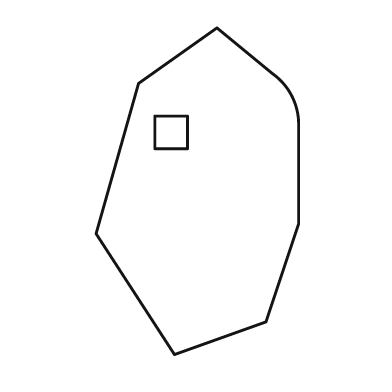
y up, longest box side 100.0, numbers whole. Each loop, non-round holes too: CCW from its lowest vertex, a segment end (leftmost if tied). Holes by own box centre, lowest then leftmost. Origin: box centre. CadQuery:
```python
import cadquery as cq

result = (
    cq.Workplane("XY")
    .moveTo(-7.0, -50.0)
    .lineTo(21.0, -40.0)
    .lineTo(31.0, -10.0)
    .lineTo(31.0, 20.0)
    .threePointArc((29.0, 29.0), (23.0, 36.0))
    .lineTo(6.0, 50.0)
    .lineTo(-18.0, 33.0)
    .lineTo(-31.0, -13.0)
    .close()
    .moveTo(-13.0, 13.0)
    .lineTo(-3.0, 13.0)
    .lineTo(-3.0, 23.0)
    .lineTo(-13.0, 23.0)
    .close()
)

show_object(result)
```